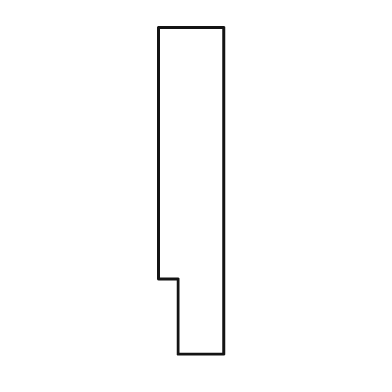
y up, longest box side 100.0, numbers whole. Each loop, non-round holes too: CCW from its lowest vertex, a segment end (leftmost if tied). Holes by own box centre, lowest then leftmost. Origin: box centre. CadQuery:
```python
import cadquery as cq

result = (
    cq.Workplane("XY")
    .moveTo(-4.0, -50.0)
    .lineTo(10.0, -50.0)
    .lineTo(10.0, 50.0)
    .lineTo(-10.0, 50.0)
    .lineTo(-10.0, -27.0)
    .lineTo(-4.0, -27.0)
    .close()
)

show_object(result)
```